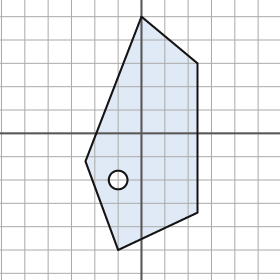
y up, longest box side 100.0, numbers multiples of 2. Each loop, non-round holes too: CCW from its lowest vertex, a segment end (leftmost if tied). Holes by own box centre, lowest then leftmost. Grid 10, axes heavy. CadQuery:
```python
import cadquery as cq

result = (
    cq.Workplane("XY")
    .moveTo(-10.0, -50.0)
    .lineTo(24.0, -34.0)
    .lineTo(24.0, 30.0)
    .lineTo(0.0, 50.0)
    .lineTo(-24.0, -12.0)
    .close()
    .moveTo(-10.0, -20.0)
    .circle(4.0)
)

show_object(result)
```